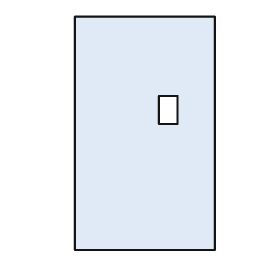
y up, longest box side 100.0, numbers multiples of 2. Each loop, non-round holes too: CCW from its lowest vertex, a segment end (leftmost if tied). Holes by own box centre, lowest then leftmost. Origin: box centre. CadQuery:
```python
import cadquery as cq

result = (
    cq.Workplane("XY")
    .moveTo(-30.0, -50.0)
    .lineTo(30.0, -50.0)
    .lineTo(30.0, 50.0)
    .lineTo(-30.0, 50.0)
    .close()
    .moveTo(6.0, 4.0)
    .lineTo(14.0, 4.0)
    .lineTo(14.0, 16.0)
    .lineTo(6.0, 16.0)
    .close()
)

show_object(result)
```